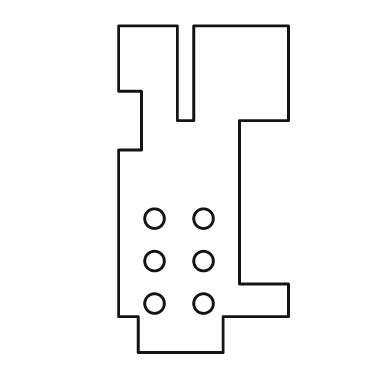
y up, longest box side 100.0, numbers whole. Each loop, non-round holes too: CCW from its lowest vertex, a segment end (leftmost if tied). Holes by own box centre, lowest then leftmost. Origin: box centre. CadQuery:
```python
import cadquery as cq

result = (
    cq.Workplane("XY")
    .moveTo(-20.0, -50.0)
    .lineTo(6.0, -50.0)
    .lineTo(6.0, -39.0)
    .lineTo(26.0, -39.0)
    .lineTo(26.0, -29.0)
    .lineTo(11.0, -29.0)
    .lineTo(11.0, 21.0)
    .lineTo(26.0, 21.0)
    .lineTo(26.0, 50.0)
    .lineTo(-3.0, 50.0)
    .lineTo(-3.0, 21.0)
    .lineTo(-8.0, 21.0)
    .lineTo(-8.0, 50.0)
    .lineTo(-26.0, 50.0)
    .lineTo(-26.0, 30.0)
    .lineTo(-19.0, 30.0)
    .lineTo(-19.0, 12.0)
    .lineTo(-26.0, 12.0)
    .lineTo(-26.0, -39.0)
    .lineTo(-20.0, -39.0)
    .close()
    .moveTo(-15.0, -35.0)
    .circle(3.0)
    .moveTo(0.0, -35.0)
    .circle(3.0)
    .moveTo(-15.0, -22.0)
    .circle(3.0)
    .moveTo(0.0, -22.0)
    .circle(3.0)
    .moveTo(-15.0, -9.0)
    .circle(3.0)
    .moveTo(0.0, -9.0)
    .circle(3.0)
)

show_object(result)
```